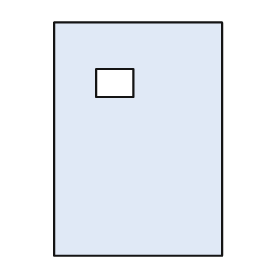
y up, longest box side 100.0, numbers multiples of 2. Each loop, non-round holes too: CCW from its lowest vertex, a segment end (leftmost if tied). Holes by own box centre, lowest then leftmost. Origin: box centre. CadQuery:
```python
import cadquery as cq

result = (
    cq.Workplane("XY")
    .moveTo(-36.0, -50.0)
    .lineTo(36.0, -50.0)
    .lineTo(36.0, 50.0)
    .lineTo(-36.0, 50.0)
    .close()
    .moveTo(-18.0, 18.0)
    .lineTo(-2.0, 18.0)
    .lineTo(-2.0, 30.0)
    .lineTo(-18.0, 30.0)
    .close()
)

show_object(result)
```